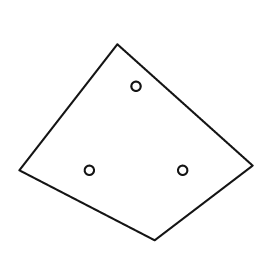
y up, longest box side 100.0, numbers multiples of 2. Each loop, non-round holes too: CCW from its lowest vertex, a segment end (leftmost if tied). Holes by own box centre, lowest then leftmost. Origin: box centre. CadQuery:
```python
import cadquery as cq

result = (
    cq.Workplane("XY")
    .moveTo(8.0, -42.0)
    .lineTo(50.0, -10.0)
    .lineTo(-8.0, 42.0)
    .lineTo(-50.0, -12.0)
    .close()
    .moveTo(-20.0, -12.0)
    .circle(2.0)
    .moveTo(20.0, -12.0)
    .circle(2.0)
    .moveTo(0.0, 24.0)
    .circle(2.0)
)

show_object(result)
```